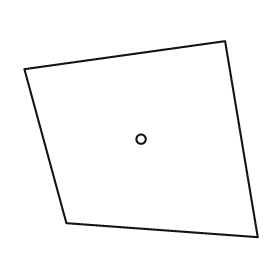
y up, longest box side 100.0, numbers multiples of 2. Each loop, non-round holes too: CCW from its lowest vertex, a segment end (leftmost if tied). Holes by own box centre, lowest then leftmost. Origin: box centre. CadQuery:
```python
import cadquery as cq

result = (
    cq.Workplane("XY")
    .moveTo(50.0, -42.0)
    .lineTo(36.0, 42.0)
    .lineTo(-50.0, 30.0)
    .lineTo(-32.0, -36.0)
    .close()
    .moveTo(0.0, 0.0)
    .circle(2.0)
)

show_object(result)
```